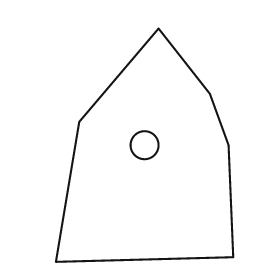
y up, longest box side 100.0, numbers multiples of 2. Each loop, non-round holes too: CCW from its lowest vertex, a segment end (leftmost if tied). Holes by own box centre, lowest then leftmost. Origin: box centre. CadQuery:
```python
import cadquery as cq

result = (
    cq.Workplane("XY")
    .moveTo(-38.0, -50.0)
    .lineTo(38.0, -48.0)
    .lineTo(36.0, 0.0)
    .lineTo(28.0, 22.0)
    .lineTo(6.0, 50.0)
    .lineTo(-28.0, 10.0)
    .close()
    .moveTo(0.0, 0.0)
    .circle(6.0)
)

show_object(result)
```